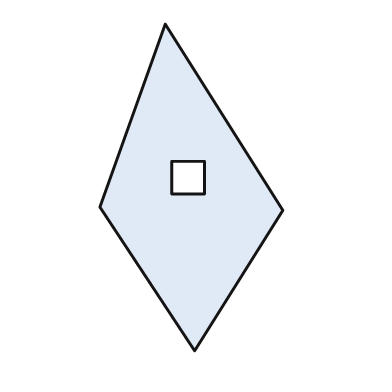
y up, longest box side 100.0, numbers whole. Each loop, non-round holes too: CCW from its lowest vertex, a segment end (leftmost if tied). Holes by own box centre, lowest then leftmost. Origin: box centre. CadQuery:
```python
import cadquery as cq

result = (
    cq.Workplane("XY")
    .moveTo(1.0, -50.0)
    .lineTo(28.0, -7.0)
    .lineTo(-8.0, 50.0)
    .lineTo(-28.0, -6.0)
    .close()
    .moveTo(-6.0, -2.0)
    .lineTo(4.0, -2.0)
    .lineTo(4.0, 8.0)
    .lineTo(-6.0, 8.0)
    .close()
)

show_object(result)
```